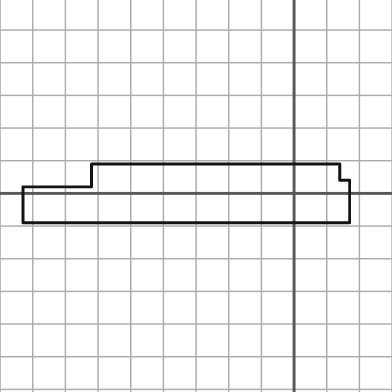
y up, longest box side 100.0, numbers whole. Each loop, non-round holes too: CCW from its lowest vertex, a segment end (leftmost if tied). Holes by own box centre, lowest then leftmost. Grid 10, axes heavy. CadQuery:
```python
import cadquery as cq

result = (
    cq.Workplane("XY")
    .moveTo(-83.0, -9.0)
    .lineTo(17.0, -9.0)
    .lineTo(17.0, 4.0)
    .lineTo(14.0, 4.0)
    .lineTo(14.0, 9.0)
    .lineTo(-62.0, 9.0)
    .lineTo(-62.0, 2.0)
    .lineTo(-83.0, 2.0)
    .close()
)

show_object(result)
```